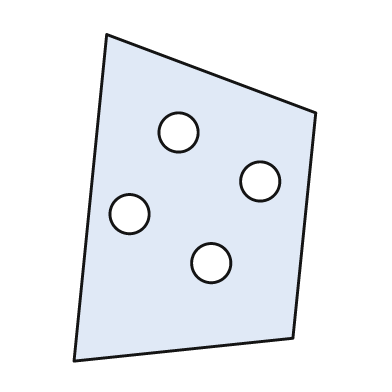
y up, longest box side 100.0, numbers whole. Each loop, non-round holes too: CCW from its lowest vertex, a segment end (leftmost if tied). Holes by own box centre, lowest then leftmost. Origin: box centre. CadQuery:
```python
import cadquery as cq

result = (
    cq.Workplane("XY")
    .moveTo(-37.0, -50.0)
    .lineTo(30.0, -43.0)
    .lineTo(37.0, 26.0)
    .lineTo(-27.0, 50.0)
    .close()
    .moveTo(5.0, -20.0)
    .circle(6.0)
    .moveTo(-20.0, -5.0)
    .circle(6.0)
    .moveTo(20.0, 5.0)
    .circle(6.0)
    .moveTo(-5.0, 20.0)
    .circle(6.0)
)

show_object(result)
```